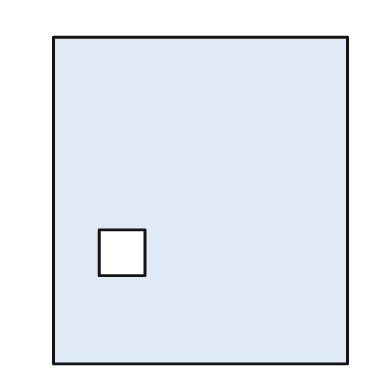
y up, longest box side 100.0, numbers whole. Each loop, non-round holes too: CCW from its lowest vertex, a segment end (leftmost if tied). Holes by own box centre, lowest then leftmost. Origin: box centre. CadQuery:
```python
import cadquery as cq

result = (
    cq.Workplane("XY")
    .moveTo(-45.0, -50.0)
    .lineTo(45.0, -50.0)
    .lineTo(45.0, 50.0)
    .lineTo(-45.0, 50.0)
    .close()
    .moveTo(-31.0, -23.0)
    .lineTo(-17.0, -23.0)
    .lineTo(-17.0, -9.0)
    .lineTo(-31.0, -9.0)
    .close()
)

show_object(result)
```